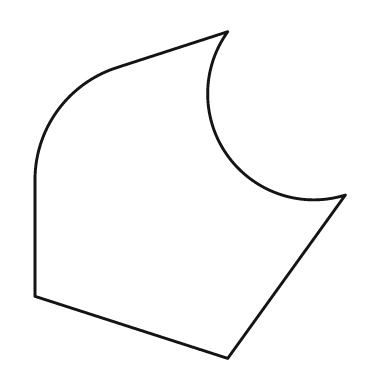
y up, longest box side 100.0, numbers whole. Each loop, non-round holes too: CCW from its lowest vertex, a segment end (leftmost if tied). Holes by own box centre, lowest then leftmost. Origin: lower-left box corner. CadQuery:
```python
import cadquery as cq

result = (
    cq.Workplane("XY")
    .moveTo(59.0, 0.0)
    .lineTo(95.0, 50.0)
    .threePointArc((59.0, 62.0), (59.0, 100.0))
    .lineTo(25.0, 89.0)
    .threePointArc((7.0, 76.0), (0.0, 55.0))
    .lineTo(0.0, 19.0)
    .close()
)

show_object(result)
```